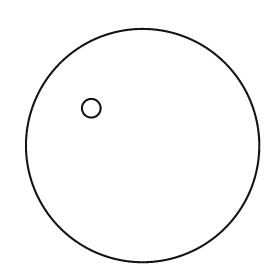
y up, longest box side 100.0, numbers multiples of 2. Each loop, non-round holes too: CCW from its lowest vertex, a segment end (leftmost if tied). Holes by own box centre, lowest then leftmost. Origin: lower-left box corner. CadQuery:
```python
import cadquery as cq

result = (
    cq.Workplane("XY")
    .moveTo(50.0, 50.0)
    .circle(50.0)
    .moveTo(28.0, 66.0)
    .circle(4.0)
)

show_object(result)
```